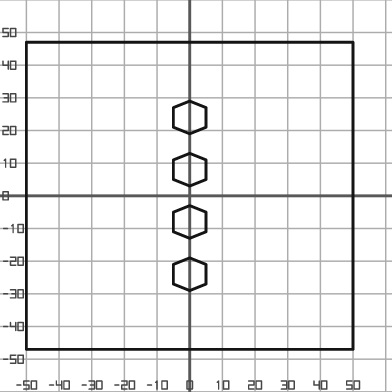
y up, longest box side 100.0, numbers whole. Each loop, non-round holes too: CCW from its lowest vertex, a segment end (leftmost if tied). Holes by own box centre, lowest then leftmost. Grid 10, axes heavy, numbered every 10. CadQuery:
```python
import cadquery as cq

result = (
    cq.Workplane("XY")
    .moveTo(-50.0, -47.0)
    .lineTo(50.0, -47.0)
    .lineTo(50.0, 47.0)
    .lineTo(-50.0, 47.0)
    .close()
    .moveTo(0.0, -29.0)
    .lineTo(5.0, -27.0)
    .lineTo(5.0, -21.0)
    .lineTo(0.0, -19.0)
    .lineTo(-5.0, -21.0)
    .lineTo(-5.0, -27.0)
    .close()
    .moveTo(0.0, -13.0)
    .lineTo(5.0, -11.0)
    .lineTo(5.0, -5.0)
    .lineTo(0.0, -3.0)
    .lineTo(-5.0, -5.0)
    .lineTo(-5.0, -11.0)
    .close()
    .moveTo(0.0, 3.0)
    .lineTo(5.0, 5.0)
    .lineTo(5.0, 11.0)
    .lineTo(0.0, 13.0)
    .lineTo(-5.0, 11.0)
    .lineTo(-5.0, 5.0)
    .close()
    .moveTo(0.0, 19.0)
    .lineTo(5.0, 21.0)
    .lineTo(5.0, 27.0)
    .lineTo(0.0, 29.0)
    .lineTo(-5.0, 27.0)
    .lineTo(-5.0, 21.0)
    .close()
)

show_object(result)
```